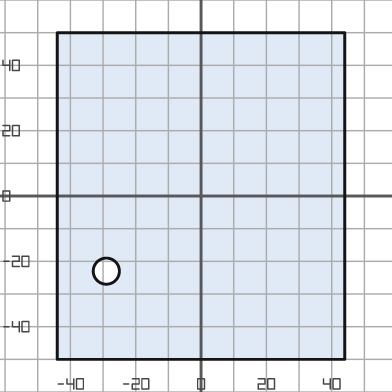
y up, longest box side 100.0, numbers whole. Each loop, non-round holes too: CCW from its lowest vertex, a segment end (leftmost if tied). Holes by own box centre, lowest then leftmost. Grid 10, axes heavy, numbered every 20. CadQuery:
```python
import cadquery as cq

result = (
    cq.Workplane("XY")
    .moveTo(-44.0, -50.0)
    .lineTo(44.0, -50.0)
    .lineTo(44.0, 50.0)
    .lineTo(-44.0, 50.0)
    .close()
    .moveTo(-29.0, -23.0)
    .circle(4.0)
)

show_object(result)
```